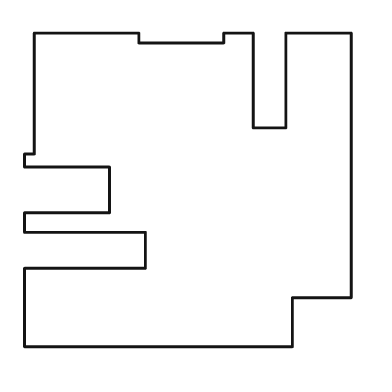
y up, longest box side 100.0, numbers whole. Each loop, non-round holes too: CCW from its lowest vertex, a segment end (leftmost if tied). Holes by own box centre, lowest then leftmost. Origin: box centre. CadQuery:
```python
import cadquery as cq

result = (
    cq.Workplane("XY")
    .moveTo(-50.0, -48.0)
    .lineTo(32.0, -48.0)
    .lineTo(32.0, -33.0)
    .lineTo(50.0, -33.0)
    .lineTo(50.0, 48.0)
    .lineTo(30.0, 48.0)
    .lineTo(30.0, 19.0)
    .lineTo(20.0, 19.0)
    .lineTo(20.0, 48.0)
    .lineTo(11.0, 48.0)
    .lineTo(11.0, 45.0)
    .lineTo(-15.0, 45.0)
    .lineTo(-15.0, 48.0)
    .lineTo(-47.0, 48.0)
    .lineTo(-47.0, 11.0)
    .lineTo(-50.0, 11.0)
    .lineTo(-50.0, 7.0)
    .lineTo(-24.0, 7.0)
    .lineTo(-24.0, -7.0)
    .lineTo(-50.0, -7.0)
    .lineTo(-50.0, -13.0)
    .lineTo(-13.0, -13.0)
    .lineTo(-13.0, -24.0)
    .lineTo(-50.0, -24.0)
    .close()
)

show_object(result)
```